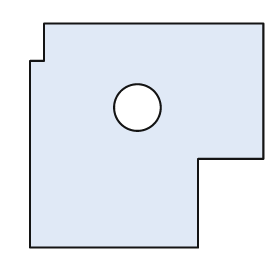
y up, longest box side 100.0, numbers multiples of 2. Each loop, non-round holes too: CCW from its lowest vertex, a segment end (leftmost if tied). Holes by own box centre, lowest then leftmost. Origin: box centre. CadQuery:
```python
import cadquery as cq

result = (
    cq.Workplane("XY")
    .moveTo(-50.0, -48.0)
    .lineTo(22.0, -48.0)
    .lineTo(22.0, -10.0)
    .lineTo(50.0, -10.0)
    .lineTo(50.0, 48.0)
    .lineTo(-44.0, 48.0)
    .lineTo(-44.0, 32.0)
    .lineTo(-50.0, 32.0)
    .close()
    .moveTo(-4.0, 12.0)
    .circle(10.0)
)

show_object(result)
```